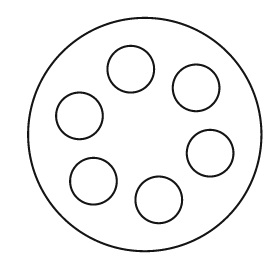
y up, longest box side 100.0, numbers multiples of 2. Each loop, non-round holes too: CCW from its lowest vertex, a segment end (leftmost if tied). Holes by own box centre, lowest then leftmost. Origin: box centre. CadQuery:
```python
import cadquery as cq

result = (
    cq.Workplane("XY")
    .moveTo(0.0, 0.0)
    .circle(50.0)
    .moveTo(6.0, -28.0)
    .circle(10.0)
    .moveTo(-22.0, -20.0)
    .circle(10.0)
    .moveTo(28.0, -8.0)
    .circle(10.0)
    .moveTo(-28.0, 8.0)
    .circle(10.0)
    .moveTo(22.0, 20.0)
    .circle(10.0)
    .moveTo(-6.0, 28.0)
    .circle(10.0)
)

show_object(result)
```